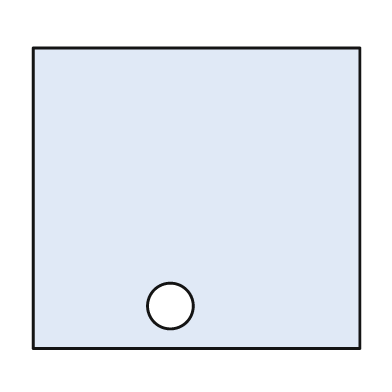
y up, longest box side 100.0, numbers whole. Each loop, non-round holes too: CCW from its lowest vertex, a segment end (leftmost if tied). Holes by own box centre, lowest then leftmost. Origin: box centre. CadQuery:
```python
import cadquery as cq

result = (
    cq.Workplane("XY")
    .moveTo(-50.0, -46.0)
    .lineTo(50.0, -46.0)
    .lineTo(50.0, 46.0)
    .lineTo(-50.0, 46.0)
    .close()
    .moveTo(-8.0, -33.0)
    .circle(7.0)
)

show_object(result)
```